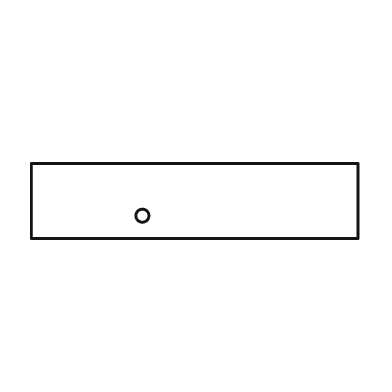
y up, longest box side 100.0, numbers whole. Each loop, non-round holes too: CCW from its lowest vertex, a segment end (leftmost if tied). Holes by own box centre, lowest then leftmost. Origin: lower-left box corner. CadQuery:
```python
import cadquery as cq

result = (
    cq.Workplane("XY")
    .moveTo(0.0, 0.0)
    .lineTo(100.0, 0.0)
    .lineTo(100.0, 23.0)
    .lineTo(0.0, 23.0)
    .close()
    .moveTo(34.0, 7.0)
    .circle(2.0)
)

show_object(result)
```